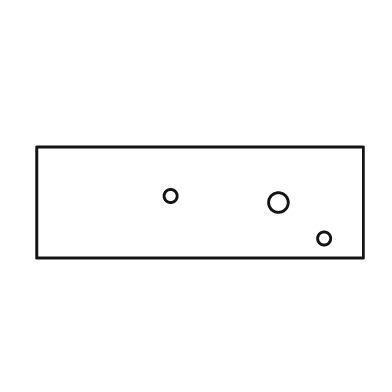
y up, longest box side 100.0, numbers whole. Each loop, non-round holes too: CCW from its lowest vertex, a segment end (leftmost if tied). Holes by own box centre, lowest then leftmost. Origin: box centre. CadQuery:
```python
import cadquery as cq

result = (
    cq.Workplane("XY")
    .moveTo(-50.0, -17.0)
    .lineTo(50.0, -17.0)
    .lineTo(50.0, 17.0)
    .lineTo(-50.0, 17.0)
    .close()
    .moveTo(38.0, -11.0)
    .circle(2.0)
    .moveTo(24.0, 0.0)
    .circle(3.0)
    .moveTo(-9.0, 2.0)
    .circle(2.0)
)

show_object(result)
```